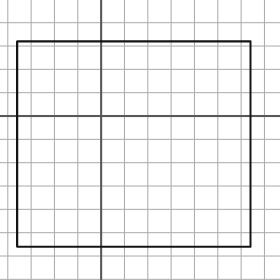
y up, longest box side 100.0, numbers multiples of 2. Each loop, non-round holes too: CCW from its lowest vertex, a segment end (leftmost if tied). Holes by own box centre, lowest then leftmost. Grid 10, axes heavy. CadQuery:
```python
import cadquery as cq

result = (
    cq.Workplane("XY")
    .moveTo(-36.0, -56.0)
    .lineTo(64.0, -56.0)
    .lineTo(64.0, 32.0)
    .lineTo(-36.0, 32.0)
    .close()
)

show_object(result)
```